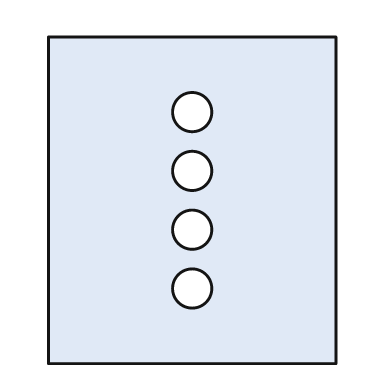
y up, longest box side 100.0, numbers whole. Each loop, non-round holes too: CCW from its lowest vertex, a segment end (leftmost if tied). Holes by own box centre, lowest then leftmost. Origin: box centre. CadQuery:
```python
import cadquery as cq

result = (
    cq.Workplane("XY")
    .moveTo(-44.0, -50.0)
    .lineTo(44.0, -50.0)
    .lineTo(44.0, 50.0)
    .lineTo(-44.0, 50.0)
    .close()
    .moveTo(0.0, -27.0)
    .circle(6.0)
    .moveTo(0.0, -9.0)
    .circle(6.0)
    .moveTo(0.0, 9.0)
    .circle(6.0)
    .moveTo(0.0, 27.0)
    .circle(6.0)
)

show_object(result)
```